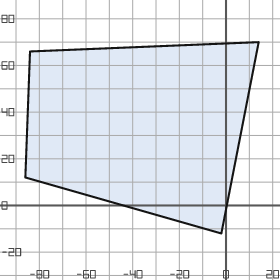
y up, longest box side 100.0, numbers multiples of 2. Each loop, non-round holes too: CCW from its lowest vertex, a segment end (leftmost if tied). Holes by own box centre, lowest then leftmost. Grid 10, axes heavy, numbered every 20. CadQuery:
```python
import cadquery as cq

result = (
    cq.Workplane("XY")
    .moveTo(-2.0, -12.0)
    .lineTo(14.0, 70.0)
    .lineTo(-84.0, 66.0)
    .lineTo(-86.0, 12.0)
    .close()
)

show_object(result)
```